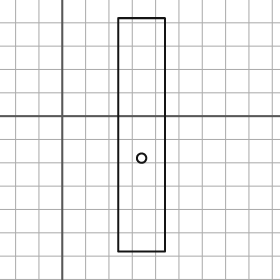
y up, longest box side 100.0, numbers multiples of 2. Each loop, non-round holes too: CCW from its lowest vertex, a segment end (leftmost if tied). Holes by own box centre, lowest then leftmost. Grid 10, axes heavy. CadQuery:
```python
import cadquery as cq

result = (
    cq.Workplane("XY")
    .moveTo(24.0, -58.0)
    .lineTo(44.0, -58.0)
    .lineTo(44.0, 42.0)
    .lineTo(24.0, 42.0)
    .close()
    .moveTo(34.0, -18.0)
    .circle(2.0)
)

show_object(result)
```